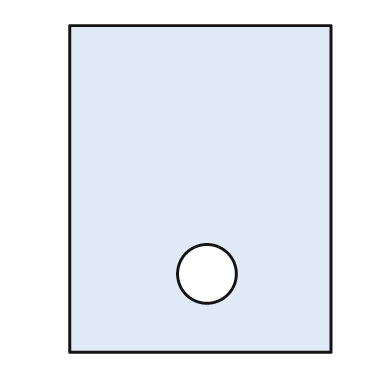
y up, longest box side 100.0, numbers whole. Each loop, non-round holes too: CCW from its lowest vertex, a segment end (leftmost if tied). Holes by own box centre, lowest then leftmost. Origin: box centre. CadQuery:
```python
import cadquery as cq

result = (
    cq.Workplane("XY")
    .moveTo(-40.0, -50.0)
    .lineTo(40.0, -50.0)
    .lineTo(40.0, 50.0)
    .lineTo(-40.0, 50.0)
    .close()
    .moveTo(2.0, -26.0)
    .circle(9.0)
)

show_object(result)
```